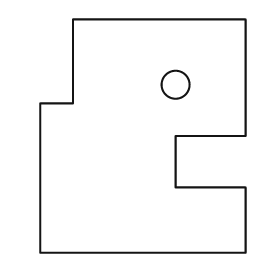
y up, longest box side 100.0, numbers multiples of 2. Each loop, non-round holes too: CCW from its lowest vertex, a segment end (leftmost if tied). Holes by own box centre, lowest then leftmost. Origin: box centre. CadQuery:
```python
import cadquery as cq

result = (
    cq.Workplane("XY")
    .moveTo(-44.0, -50.0)
    .lineTo(44.0, -50.0)
    .lineTo(44.0, -22.0)
    .lineTo(14.0, -22.0)
    .lineTo(14.0, 0.0)
    .lineTo(44.0, 0.0)
    .lineTo(44.0, 50.0)
    .lineTo(-30.0, 50.0)
    .lineTo(-30.0, 14.0)
    .lineTo(-44.0, 14.0)
    .close()
    .moveTo(14.0, 22.0)
    .circle(6.0)
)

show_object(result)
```